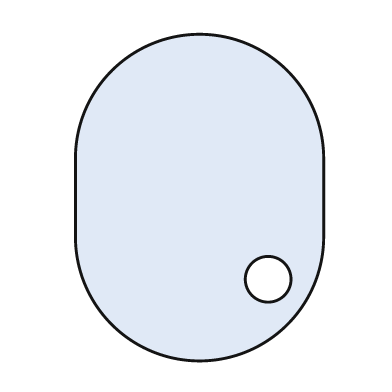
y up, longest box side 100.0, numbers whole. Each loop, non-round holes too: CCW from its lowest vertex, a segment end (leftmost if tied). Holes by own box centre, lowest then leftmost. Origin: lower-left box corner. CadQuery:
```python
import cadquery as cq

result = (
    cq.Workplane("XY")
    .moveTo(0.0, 38.0)
    .threePointArc((38.0, 0.0), (76.0, 38.0))
    .lineTo(76.0, 62.0)
    .threePointArc((38.0, 100.0), (0.0, 62.0))
    .close()
    .moveTo(59.0, 25.0)
    .circle(7.0)
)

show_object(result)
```